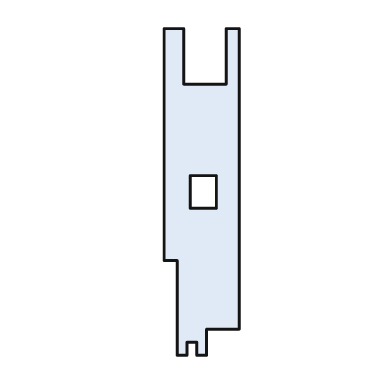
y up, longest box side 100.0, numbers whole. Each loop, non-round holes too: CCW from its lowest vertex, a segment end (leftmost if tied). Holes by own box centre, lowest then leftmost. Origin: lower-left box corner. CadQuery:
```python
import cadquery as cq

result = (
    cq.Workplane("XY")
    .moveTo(4.0, 0.0)
    .lineTo(7.0, 0.0)
    .lineTo(7.0, 4.0)
    .lineTo(10.0, 4.0)
    .lineTo(10.0, 0.0)
    .lineTo(13.0, 0.0)
    .lineTo(13.0, 8.0)
    .lineTo(23.0, 8.0)
    .lineTo(23.0, 100.0)
    .lineTo(19.0, 100.0)
    .lineTo(19.0, 83.0)
    .lineTo(6.0, 83.0)
    .lineTo(6.0, 100.0)
    .lineTo(0.0, 100.0)
    .lineTo(0.0, 29.0)
    .lineTo(4.0, 29.0)
    .close()
    .moveTo(8.0, 45.0)
    .lineTo(16.0, 45.0)
    .lineTo(16.0, 55.0)
    .lineTo(8.0, 55.0)
    .close()
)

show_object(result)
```